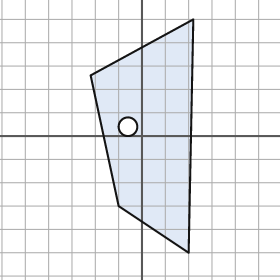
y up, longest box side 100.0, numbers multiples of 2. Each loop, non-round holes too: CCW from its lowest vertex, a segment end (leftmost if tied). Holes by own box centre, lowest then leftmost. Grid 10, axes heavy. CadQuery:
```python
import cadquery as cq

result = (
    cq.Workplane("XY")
    .moveTo(20.0, -50.0)
    .lineTo(22.0, 50.0)
    .lineTo(-22.0, 26.0)
    .lineTo(-10.0, -30.0)
    .close()
    .moveTo(-6.0, 4.0)
    .circle(4.0)
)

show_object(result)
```